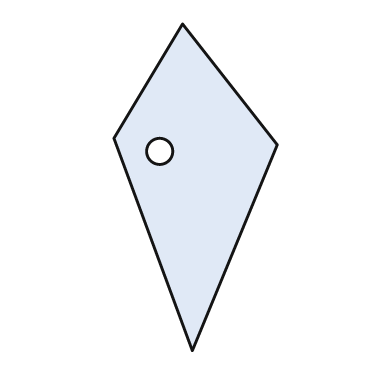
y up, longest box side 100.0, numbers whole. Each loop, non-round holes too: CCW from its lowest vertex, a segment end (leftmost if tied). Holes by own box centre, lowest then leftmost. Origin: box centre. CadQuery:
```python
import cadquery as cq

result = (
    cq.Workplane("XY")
    .moveTo(-1.0, -50.0)
    .lineTo(25.0, 13.0)
    .lineTo(-4.0, 50.0)
    .lineTo(-25.0, 15.0)
    .close()
    .moveTo(-11.0, 11.0)
    .circle(4.0)
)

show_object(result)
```